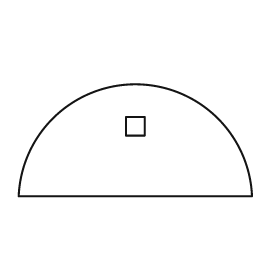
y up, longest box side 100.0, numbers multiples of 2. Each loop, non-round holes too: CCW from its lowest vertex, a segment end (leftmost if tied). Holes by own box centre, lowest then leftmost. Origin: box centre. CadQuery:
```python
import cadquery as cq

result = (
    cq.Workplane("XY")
    .moveTo(-50.0, -24.0)
    .lineTo(50.0, -24.0)
    .threePointArc((0.0, 24.0), (-50.0, -24.0))
    .close()
    .moveTo(-4.0, 2.0)
    .lineTo(4.0, 2.0)
    .lineTo(4.0, 10.0)
    .lineTo(-4.0, 10.0)
    .close()
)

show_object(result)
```